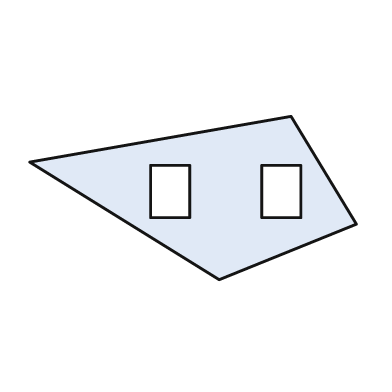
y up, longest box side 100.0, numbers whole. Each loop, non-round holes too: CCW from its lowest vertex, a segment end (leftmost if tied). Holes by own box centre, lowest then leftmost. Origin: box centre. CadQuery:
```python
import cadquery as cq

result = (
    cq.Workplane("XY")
    .moveTo(8.0, -25.0)
    .lineTo(50.0, -8.0)
    .lineTo(30.0, 25.0)
    .lineTo(-50.0, 11.0)
    .close()
    .moveTo(-13.0, -6.0)
    .lineTo(-1.0, -6.0)
    .lineTo(-1.0, 10.0)
    .lineTo(-13.0, 10.0)
    .close()
    .moveTo(21.0, -6.0)
    .lineTo(33.0, -6.0)
    .lineTo(33.0, 10.0)
    .lineTo(21.0, 10.0)
    .close()
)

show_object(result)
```